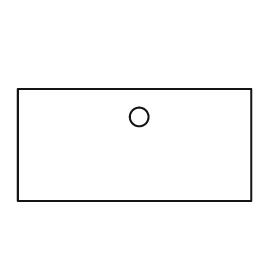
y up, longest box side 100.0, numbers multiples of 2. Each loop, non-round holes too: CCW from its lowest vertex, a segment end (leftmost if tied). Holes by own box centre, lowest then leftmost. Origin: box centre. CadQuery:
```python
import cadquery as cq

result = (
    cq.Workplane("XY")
    .moveTo(-50.0, -24.0)
    .lineTo(50.0, -24.0)
    .lineTo(50.0, 24.0)
    .lineTo(-50.0, 24.0)
    .close()
    .moveTo(2.0, 12.0)
    .circle(4.0)
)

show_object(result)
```